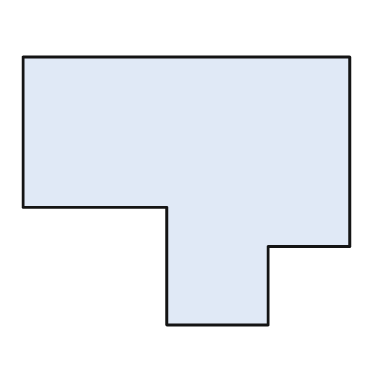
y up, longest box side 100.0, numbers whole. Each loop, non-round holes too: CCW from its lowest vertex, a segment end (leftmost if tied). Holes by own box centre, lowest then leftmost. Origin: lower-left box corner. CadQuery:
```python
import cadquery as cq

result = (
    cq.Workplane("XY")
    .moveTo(44.0, 0.0)
    .lineTo(75.0, 0.0)
    .lineTo(75.0, 24.0)
    .lineTo(100.0, 24.0)
    .lineTo(100.0, 82.0)
    .lineTo(0.0, 82.0)
    .lineTo(0.0, 36.0)
    .lineTo(44.0, 36.0)
    .close()
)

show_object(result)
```